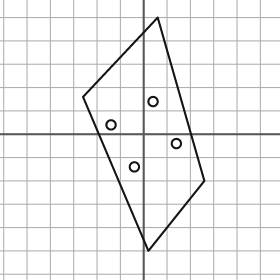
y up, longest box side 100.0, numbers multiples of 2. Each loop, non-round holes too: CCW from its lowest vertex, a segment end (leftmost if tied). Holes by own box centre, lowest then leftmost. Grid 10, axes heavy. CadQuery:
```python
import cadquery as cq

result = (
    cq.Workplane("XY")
    .moveTo(2.0, -50.0)
    .lineTo(26.0, -20.0)
    .lineTo(6.0, 50.0)
    .lineTo(-26.0, 16.0)
    .close()
    .moveTo(-4.0, -14.0)
    .circle(2.0)
    .moveTo(14.0, -4.0)
    .circle(2.0)
    .moveTo(-14.0, 4.0)
    .circle(2.0)
    .moveTo(4.0, 14.0)
    .circle(2.0)
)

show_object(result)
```